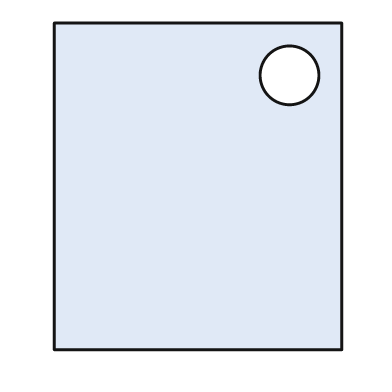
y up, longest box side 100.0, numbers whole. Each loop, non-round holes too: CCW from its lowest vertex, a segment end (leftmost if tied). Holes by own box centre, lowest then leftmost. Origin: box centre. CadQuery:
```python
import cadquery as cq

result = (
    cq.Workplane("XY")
    .moveTo(-44.0, -50.0)
    .lineTo(44.0, -50.0)
    .lineTo(44.0, 50.0)
    .lineTo(-44.0, 50.0)
    .close()
    .moveTo(28.0, 34.0)
    .circle(9.0)
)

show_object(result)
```